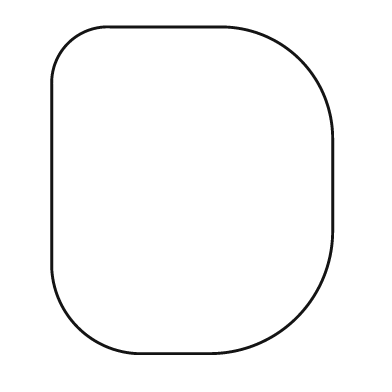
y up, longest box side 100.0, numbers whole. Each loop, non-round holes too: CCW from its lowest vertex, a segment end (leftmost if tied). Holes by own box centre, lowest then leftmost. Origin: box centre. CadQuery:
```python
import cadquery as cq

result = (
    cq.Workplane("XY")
    .moveTo(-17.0, -50.0)
    .lineTo(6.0, -50.0)
    .threePointArc((32.0, -39.0), (43.0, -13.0))
    .lineTo(43.0, 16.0)
    .threePointArc((33.0, 40.0), (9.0, 50.0))
    .lineTo(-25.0, 50.0)
    .threePointArc((-38.0, 45.0), (-43.0, 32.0))
    .lineTo(-43.0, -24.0)
    .threePointArc((-35.0, -42.0), (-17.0, -50.0))
    .close()
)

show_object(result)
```